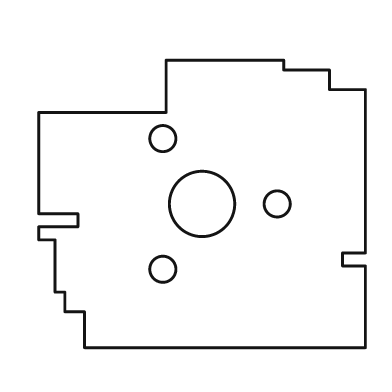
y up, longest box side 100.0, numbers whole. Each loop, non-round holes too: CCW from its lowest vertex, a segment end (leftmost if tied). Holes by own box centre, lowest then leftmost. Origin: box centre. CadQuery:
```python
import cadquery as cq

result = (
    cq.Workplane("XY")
    .moveTo(-36.0, -44.0)
    .lineTo(50.0, -44.0)
    .lineTo(50.0, -19.0)
    .lineTo(43.0, -19.0)
    .lineTo(43.0, -15.0)
    .lineTo(50.0, -15.0)
    .lineTo(50.0, 35.0)
    .lineTo(39.0, 35.0)
    .lineTo(39.0, 41.0)
    .lineTo(25.0, 41.0)
    .lineTo(25.0, 44.0)
    .lineTo(-11.0, 44.0)
    .lineTo(-11.0, 28.0)
    .lineTo(-50.0, 28.0)
    .lineTo(-50.0, -3.0)
    .lineTo(-38.0, -3.0)
    .lineTo(-38.0, -7.0)
    .lineTo(-50.0, -7.0)
    .lineTo(-50.0, -11.0)
    .lineTo(-45.0, -11.0)
    .lineTo(-45.0, -27.0)
    .lineTo(-42.0, -27.0)
    .lineTo(-42.0, -33.0)
    .lineTo(-36.0, -33.0)
    .close()
    .moveTo(-12.0, -20.0)
    .circle(4.0)
    .moveTo(0.0, 0.0)
    .circle(10.0)
    .moveTo(23.0, 0.0)
    .circle(4.0)
    .moveTo(-12.0, 20.0)
    .circle(4.0)
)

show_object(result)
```